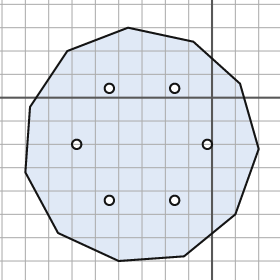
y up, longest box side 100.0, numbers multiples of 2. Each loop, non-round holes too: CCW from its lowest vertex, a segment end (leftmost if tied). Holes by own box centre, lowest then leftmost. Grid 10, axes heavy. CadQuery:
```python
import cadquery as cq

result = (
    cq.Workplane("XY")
    .moveTo(-40.0, -70.0)
    .lineTo(-12.0, -68.0)
    .lineTo(10.0, -50.0)
    .lineTo(20.0, -22.0)
    .lineTo(12.0, 6.0)
    .lineTo(-8.0, 24.0)
    .lineTo(-36.0, 30.0)
    .lineTo(-62.0, 20.0)
    .lineTo(-78.0, -4.0)
    .lineTo(-80.0, -32.0)
    .lineTo(-66.0, -58.0)
    .close()
    .moveTo(-44.0, -44.0)
    .circle(2.0)
    .moveTo(-16.0, -44.0)
    .circle(2.0)
    .moveTo(-58.0, -20.0)
    .circle(2.0)
    .moveTo(-2.0, -20.0)
    .circle(2.0)
    .moveTo(-44.0, 4.0)
    .circle(2.0)
    .moveTo(-16.0, 4.0)
    .circle(2.0)
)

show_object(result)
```